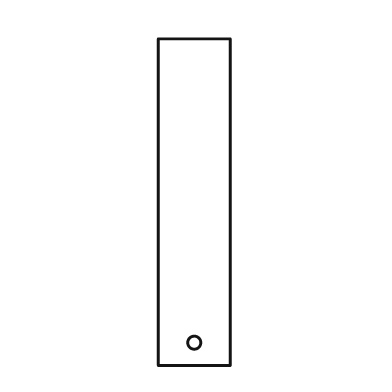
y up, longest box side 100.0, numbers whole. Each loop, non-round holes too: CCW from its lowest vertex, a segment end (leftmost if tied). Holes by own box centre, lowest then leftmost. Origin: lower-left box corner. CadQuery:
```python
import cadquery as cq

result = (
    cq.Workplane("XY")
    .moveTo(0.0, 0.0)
    .lineTo(22.0, 0.0)
    .lineTo(22.0, 100.0)
    .lineTo(0.0, 100.0)
    .close()
    .moveTo(11.0, 7.0)
    .circle(2.0)
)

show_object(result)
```